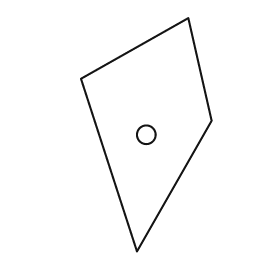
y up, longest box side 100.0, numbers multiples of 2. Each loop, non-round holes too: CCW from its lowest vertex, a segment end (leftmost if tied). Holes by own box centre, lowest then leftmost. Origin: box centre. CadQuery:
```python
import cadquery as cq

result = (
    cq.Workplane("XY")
    .moveTo(-4.0, -50.0)
    .lineTo(28.0, 6.0)
    .lineTo(18.0, 50.0)
    .lineTo(-28.0, 24.0)
    .close()
    .moveTo(0.0, 0.0)
    .circle(4.0)
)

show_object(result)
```